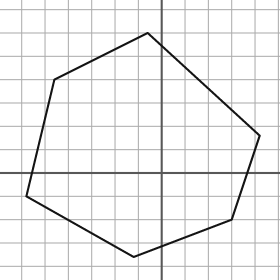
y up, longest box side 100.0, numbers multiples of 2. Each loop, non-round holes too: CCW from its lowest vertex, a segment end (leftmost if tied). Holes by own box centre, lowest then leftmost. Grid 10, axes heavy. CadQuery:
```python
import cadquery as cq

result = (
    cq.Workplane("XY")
    .moveTo(-12.0, -36.0)
    .lineTo(30.0, -20.0)
    .lineTo(42.0, 16.0)
    .lineTo(-6.0, 60.0)
    .lineTo(-46.0, 40.0)
    .lineTo(-58.0, -10.0)
    .close()
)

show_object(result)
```